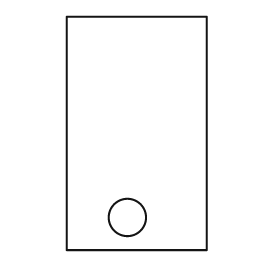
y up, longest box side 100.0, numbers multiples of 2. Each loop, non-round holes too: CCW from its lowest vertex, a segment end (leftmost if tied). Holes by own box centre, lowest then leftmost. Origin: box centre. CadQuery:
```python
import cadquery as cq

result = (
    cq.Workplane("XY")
    .moveTo(-30.0, -50.0)
    .lineTo(30.0, -50.0)
    .lineTo(30.0, 50.0)
    .lineTo(-30.0, 50.0)
    .close()
    .moveTo(-4.0, -36.0)
    .circle(8.0)
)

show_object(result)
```